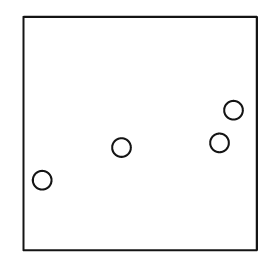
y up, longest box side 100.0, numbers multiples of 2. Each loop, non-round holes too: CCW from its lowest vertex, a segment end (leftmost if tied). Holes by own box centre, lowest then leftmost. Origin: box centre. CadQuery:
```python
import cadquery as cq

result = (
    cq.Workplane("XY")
    .moveTo(-50.0, -50.0)
    .lineTo(50.0, -50.0)
    .lineTo(50.0, 50.0)
    .lineTo(-50.0, 50.0)
    .close()
    .moveTo(-42.0, -20.0)
    .circle(4.0)
    .moveTo(-8.0, -6.0)
    .circle(4.0)
    .moveTo(34.0, -4.0)
    .circle(4.0)
    .moveTo(40.0, 10.0)
    .circle(4.0)
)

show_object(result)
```